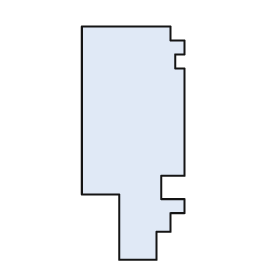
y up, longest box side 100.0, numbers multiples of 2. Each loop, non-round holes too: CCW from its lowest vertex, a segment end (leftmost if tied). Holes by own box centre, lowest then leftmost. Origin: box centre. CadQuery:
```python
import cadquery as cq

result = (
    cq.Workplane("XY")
    .moveTo(-6.0, -50.0)
    .lineTo(10.0, -50.0)
    .lineTo(10.0, -38.0)
    .lineTo(16.0, -38.0)
    .lineTo(16.0, -30.0)
    .lineTo(22.0, -30.0)
    .lineTo(22.0, -24.0)
    .lineTo(12.0, -24.0)
    .lineTo(12.0, -14.0)
    .lineTo(22.0, -14.0)
    .lineTo(22.0, 32.0)
    .lineTo(18.0, 32.0)
    .lineTo(18.0, 38.0)
    .lineTo(22.0, 38.0)
    .lineTo(22.0, 44.0)
    .lineTo(16.0, 44.0)
    .lineTo(16.0, 50.0)
    .lineTo(-22.0, 50.0)
    .lineTo(-22.0, -22.0)
    .lineTo(-6.0, -22.0)
    .close()
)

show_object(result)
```